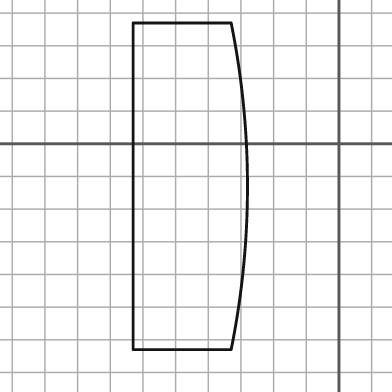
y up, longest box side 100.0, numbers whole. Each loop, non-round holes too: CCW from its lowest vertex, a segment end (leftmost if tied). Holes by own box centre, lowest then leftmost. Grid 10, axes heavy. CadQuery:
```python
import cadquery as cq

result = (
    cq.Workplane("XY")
    .moveTo(-63.0, -63.0)
    .lineTo(-33.0, -63.0)
    .threePointArc((-28.0, -13.0), (-33.0, 37.0))
    .lineTo(-63.0, 37.0)
    .close()
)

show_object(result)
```